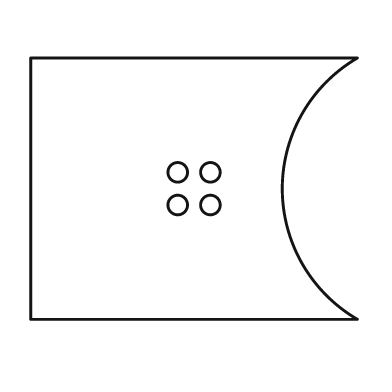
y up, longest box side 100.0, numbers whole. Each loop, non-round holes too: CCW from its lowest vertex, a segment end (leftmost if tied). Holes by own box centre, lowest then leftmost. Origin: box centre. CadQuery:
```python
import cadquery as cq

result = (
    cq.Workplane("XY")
    .moveTo(-50.0, -40.0)
    .lineTo(50.0, -40.0)
    .threePointArc((27.0, 0.0), (50.0, 40.0))
    .lineTo(-50.0, 40.0)
    .close()
    .moveTo(-5.0, -5.0)
    .circle(3.0)
    .moveTo(5.0, -5.0)
    .circle(3.0)
    .moveTo(-5.0, 5.0)
    .circle(3.0)
    .moveTo(5.0, 5.0)
    .circle(3.0)
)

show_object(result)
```